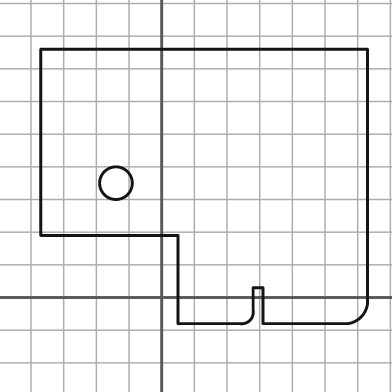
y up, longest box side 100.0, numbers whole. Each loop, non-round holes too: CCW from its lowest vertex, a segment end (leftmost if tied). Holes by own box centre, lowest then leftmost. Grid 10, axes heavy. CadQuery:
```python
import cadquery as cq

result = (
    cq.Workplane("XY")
    .moveTo(5.0, -8.0)
    .lineTo(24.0, -8.0)
    .threePointArc((27.0, -7.0), (28.0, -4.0))
    .lineTo(28.0, 3.0)
    .lineTo(31.0, 3.0)
    .lineTo(31.0, -8.0)
    .lineTo(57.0, -8.0)
    .threePointArc((61.0, -6.0), (63.0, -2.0))
    .lineTo(63.0, 76.0)
    .lineTo(-37.0, 76.0)
    .lineTo(-37.0, 19.0)
    .lineTo(5.0, 19.0)
    .close()
    .moveTo(-14.0, 35.0)
    .circle(5.0)
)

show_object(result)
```